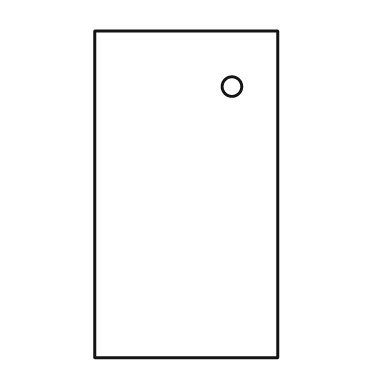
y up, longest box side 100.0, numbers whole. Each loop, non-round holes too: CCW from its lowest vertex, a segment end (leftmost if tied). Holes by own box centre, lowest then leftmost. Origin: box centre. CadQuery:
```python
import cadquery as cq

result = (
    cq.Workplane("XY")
    .moveTo(-28.0, -50.0)
    .lineTo(28.0, -50.0)
    .lineTo(28.0, 50.0)
    .lineTo(-28.0, 50.0)
    .close()
    .moveTo(14.0, 33.0)
    .circle(3.0)
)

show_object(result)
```